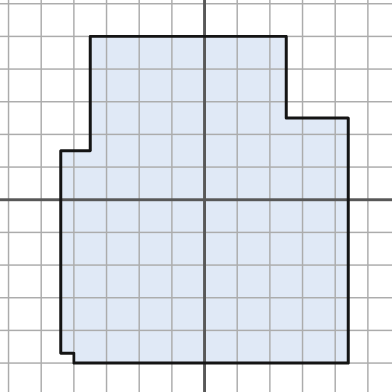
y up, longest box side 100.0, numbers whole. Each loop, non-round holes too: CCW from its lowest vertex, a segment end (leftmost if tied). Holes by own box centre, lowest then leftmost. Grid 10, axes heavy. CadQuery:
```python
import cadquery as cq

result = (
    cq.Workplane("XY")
    .moveTo(-40.0, -50.0)
    .lineTo(44.0, -50.0)
    .lineTo(44.0, 25.0)
    .lineTo(25.0, 25.0)
    .lineTo(25.0, 50.0)
    .lineTo(-35.0, 50.0)
    .lineTo(-35.0, 15.0)
    .lineTo(-44.0, 15.0)
    .lineTo(-44.0, -47.0)
    .lineTo(-40.0, -47.0)
    .close()
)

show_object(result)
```